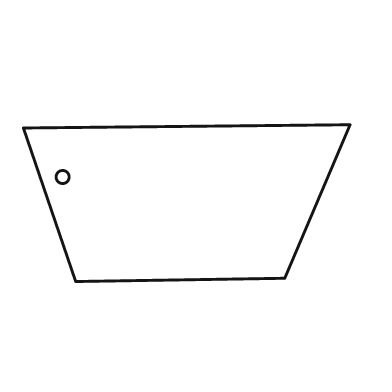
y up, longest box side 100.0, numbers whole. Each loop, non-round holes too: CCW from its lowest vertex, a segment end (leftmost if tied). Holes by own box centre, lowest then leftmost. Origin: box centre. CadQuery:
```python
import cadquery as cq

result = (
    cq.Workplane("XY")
    .moveTo(-34.0, -24.0)
    .lineTo(30.0, -23.0)
    .lineTo(50.0, 24.0)
    .lineTo(-50.0, 23.0)
    .close()
    .moveTo(-38.0, 8.0)
    .circle(2.0)
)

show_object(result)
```